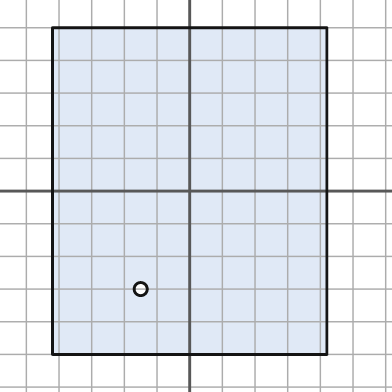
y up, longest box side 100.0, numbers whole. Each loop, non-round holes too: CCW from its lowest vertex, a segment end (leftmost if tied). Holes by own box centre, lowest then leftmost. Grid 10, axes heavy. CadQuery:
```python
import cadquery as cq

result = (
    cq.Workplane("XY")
    .moveTo(-42.0, -50.0)
    .lineTo(42.0, -50.0)
    .lineTo(42.0, 50.0)
    .lineTo(-42.0, 50.0)
    .close()
    .moveTo(-15.0, -30.0)
    .circle(2.0)
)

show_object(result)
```